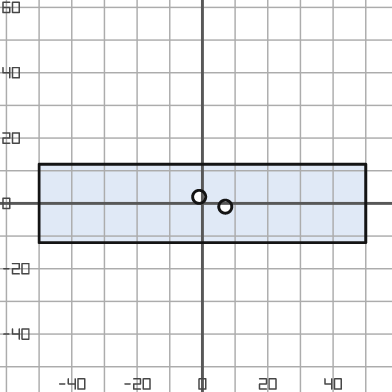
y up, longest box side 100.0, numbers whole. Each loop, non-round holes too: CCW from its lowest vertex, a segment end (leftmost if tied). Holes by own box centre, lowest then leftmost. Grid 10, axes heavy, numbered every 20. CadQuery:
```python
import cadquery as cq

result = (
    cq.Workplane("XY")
    .moveTo(-50.0, -12.0)
    .lineTo(50.0, -12.0)
    .lineTo(50.0, 12.0)
    .lineTo(-50.0, 12.0)
    .close()
    .moveTo(7.0, -1.0)
    .circle(2.0)
    .moveTo(-1.0, 2.0)
    .circle(2.0)
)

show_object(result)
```